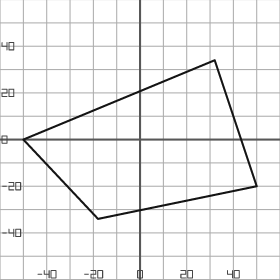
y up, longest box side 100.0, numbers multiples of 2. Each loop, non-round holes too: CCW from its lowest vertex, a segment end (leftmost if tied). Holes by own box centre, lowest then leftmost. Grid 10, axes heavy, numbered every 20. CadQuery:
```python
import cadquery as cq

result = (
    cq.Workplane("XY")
    .moveTo(-18.0, -34.0)
    .lineTo(50.0, -20.0)
    .lineTo(32.0, 34.0)
    .lineTo(-50.0, 0.0)
    .close()
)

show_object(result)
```